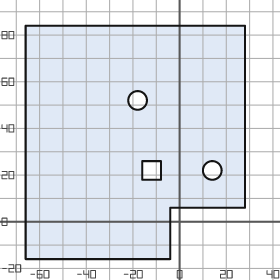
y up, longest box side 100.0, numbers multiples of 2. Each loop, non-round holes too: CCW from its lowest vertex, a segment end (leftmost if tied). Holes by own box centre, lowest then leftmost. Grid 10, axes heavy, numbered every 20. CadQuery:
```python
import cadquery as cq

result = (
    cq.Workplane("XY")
    .moveTo(-66.0, -16.0)
    .lineTo(-4.0, -16.0)
    .lineTo(-4.0, 6.0)
    .lineTo(28.0, 6.0)
    .lineTo(28.0, 84.0)
    .lineTo(-66.0, 84.0)
    .close()
    .moveTo(-16.0, 18.0)
    .lineTo(-8.0, 18.0)
    .lineTo(-8.0, 26.0)
    .lineTo(-16.0, 26.0)
    .close()
    .moveTo(14.0, 22.0)
    .circle(4.0)
    .moveTo(-18.0, 52.0)
    .circle(4.0)
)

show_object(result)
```